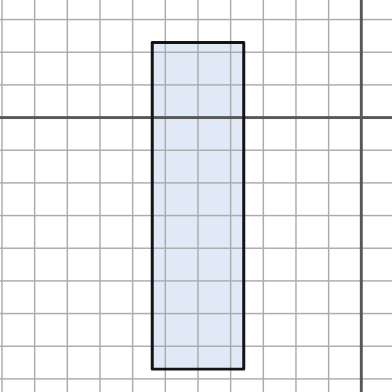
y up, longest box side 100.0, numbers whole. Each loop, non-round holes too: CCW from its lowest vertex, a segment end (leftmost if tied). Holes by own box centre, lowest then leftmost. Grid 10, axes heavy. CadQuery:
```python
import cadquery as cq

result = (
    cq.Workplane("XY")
    .moveTo(-64.0, -77.0)
    .lineTo(-36.0, -77.0)
    .lineTo(-36.0, 23.0)
    .lineTo(-64.0, 23.0)
    .close()
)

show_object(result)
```